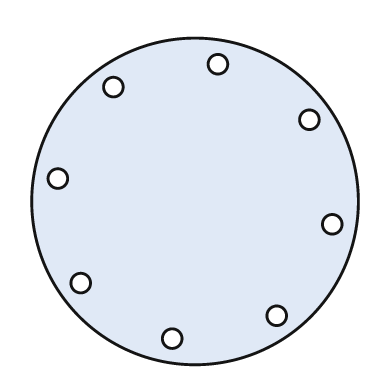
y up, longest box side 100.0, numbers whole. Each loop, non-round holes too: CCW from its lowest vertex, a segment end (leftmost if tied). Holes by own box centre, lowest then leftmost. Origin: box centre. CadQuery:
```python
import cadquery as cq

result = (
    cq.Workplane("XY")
    .moveTo(0.0, 0.0)
    .circle(50.0)
    .moveTo(-7.0, -42.0)
    .circle(3.0)
    .moveTo(25.0, -35.0)
    .circle(3.0)
    .moveTo(-35.0, -25.0)
    .circle(3.0)
    .moveTo(42.0, -7.0)
    .circle(3.0)
    .moveTo(-42.0, 7.0)
    .circle(3.0)
    .moveTo(35.0, 25.0)
    .circle(3.0)
    .moveTo(-25.0, 35.0)
    .circle(3.0)
    .moveTo(7.0, 42.0)
    .circle(3.0)
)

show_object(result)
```